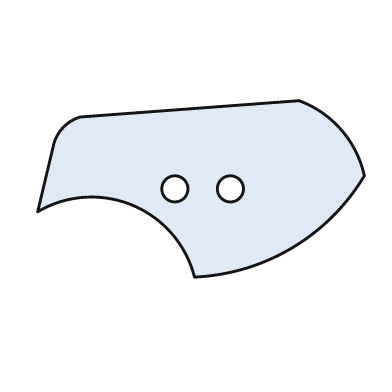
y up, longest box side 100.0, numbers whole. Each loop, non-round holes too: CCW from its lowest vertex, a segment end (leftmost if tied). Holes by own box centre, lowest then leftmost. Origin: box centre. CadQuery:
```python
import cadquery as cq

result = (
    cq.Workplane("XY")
    .moveTo(-2.0, -27.0)
    .threePointArc((28.0, -18.0), (50.0, 4.0))
    .threePointArc((43.0, 18.0), (30.0, 27.0))
    .lineTo(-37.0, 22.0)
    .threePointArc((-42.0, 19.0), (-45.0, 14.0))
    .lineTo(-50.0, -7.0)
    .threePointArc((-21.0, -5.0), (-2.0, -27.0))
    .close()
    .moveTo(-8.0, 0.0)
    .circle(4.0)
    .moveTo(9.0, 0.0)
    .circle(4.0)
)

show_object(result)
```